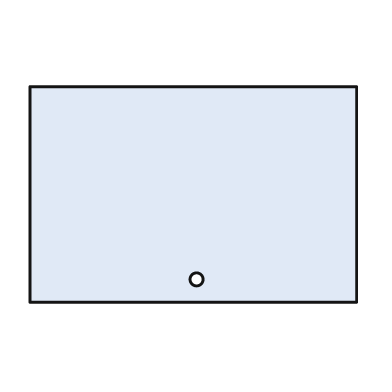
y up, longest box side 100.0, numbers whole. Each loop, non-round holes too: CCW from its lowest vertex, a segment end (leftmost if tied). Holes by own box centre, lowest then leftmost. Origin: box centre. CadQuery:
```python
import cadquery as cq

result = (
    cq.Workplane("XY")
    .moveTo(-50.0, -33.0)
    .lineTo(50.0, -33.0)
    .lineTo(50.0, 33.0)
    .lineTo(-50.0, 33.0)
    .close()
    .moveTo(1.0, -26.0)
    .circle(2.0)
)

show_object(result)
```